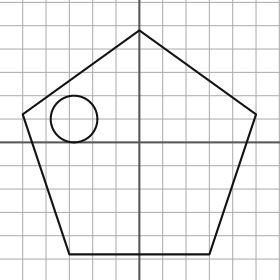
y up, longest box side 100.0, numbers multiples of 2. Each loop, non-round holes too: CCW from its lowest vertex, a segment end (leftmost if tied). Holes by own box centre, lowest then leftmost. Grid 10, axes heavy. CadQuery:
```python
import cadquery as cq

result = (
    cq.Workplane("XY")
    .moveTo(-30.0, -48.0)
    .lineTo(30.0, -48.0)
    .lineTo(50.0, 12.0)
    .lineTo(0.0, 48.0)
    .lineTo(-50.0, 12.0)
    .close()
    .moveTo(-28.0, 10.0)
    .circle(10.0)
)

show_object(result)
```